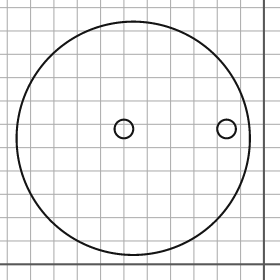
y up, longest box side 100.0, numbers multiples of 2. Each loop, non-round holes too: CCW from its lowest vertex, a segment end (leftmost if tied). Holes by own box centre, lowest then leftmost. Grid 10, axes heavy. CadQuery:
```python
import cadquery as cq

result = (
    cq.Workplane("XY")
    .moveTo(-56.0, 54.0)
    .circle(50.0)
    .moveTo(-60.0, 58.0)
    .circle(4.0)
    .moveTo(-16.0, 58.0)
    .circle(4.0)
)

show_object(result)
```